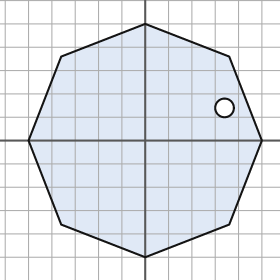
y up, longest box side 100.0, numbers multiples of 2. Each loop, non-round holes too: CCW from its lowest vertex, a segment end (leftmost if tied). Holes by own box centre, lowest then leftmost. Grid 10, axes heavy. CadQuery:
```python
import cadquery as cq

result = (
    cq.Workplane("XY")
    .moveTo(0.0, -50.0)
    .lineTo(36.0, -36.0)
    .lineTo(50.0, 0.0)
    .lineTo(36.0, 36.0)
    .lineTo(0.0, 50.0)
    .lineTo(-36.0, 36.0)
    .lineTo(-50.0, 0.0)
    .lineTo(-36.0, -36.0)
    .close()
    .moveTo(34.0, 14.0)
    .circle(4.0)
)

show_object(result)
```